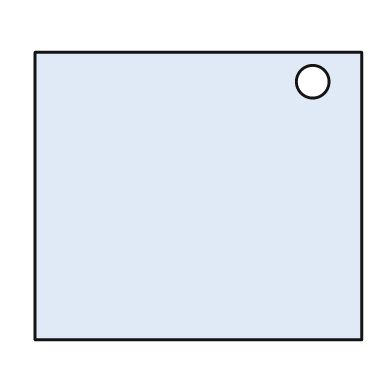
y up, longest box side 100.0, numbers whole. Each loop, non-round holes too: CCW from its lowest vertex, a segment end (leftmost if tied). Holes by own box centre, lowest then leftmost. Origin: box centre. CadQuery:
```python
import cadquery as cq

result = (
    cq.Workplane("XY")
    .moveTo(-50.0, -44.0)
    .lineTo(50.0, -44.0)
    .lineTo(50.0, 44.0)
    .lineTo(-50.0, 44.0)
    .close()
    .moveTo(35.0, 35.0)
    .circle(5.0)
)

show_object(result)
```